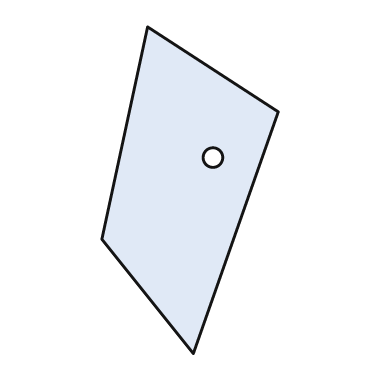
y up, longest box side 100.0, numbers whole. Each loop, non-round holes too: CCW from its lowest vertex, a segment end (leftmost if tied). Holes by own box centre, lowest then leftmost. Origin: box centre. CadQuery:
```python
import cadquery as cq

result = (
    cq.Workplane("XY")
    .moveTo(1.0, -50.0)
    .lineTo(27.0, 24.0)
    .lineTo(-13.0, 50.0)
    .lineTo(-27.0, -15.0)
    .close()
    .moveTo(7.0, 10.0)
    .circle(3.0)
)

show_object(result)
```